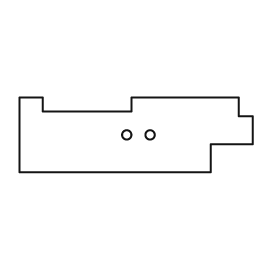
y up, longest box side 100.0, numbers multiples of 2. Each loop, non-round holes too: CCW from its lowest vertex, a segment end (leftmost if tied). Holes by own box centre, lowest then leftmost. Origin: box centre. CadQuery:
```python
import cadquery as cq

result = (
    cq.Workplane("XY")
    .moveTo(-50.0, -16.0)
    .lineTo(32.0, -16.0)
    .lineTo(32.0, -4.0)
    .lineTo(50.0, -4.0)
    .lineTo(50.0, 8.0)
    .lineTo(44.0, 8.0)
    .lineTo(44.0, 16.0)
    .lineTo(-2.0, 16.0)
    .lineTo(-2.0, 10.0)
    .lineTo(-40.0, 10.0)
    .lineTo(-40.0, 16.0)
    .lineTo(-50.0, 16.0)
    .close()
    .moveTo(-4.0, 0.0)
    .circle(2.0)
    .moveTo(6.0, 0.0)
    .circle(2.0)
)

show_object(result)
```